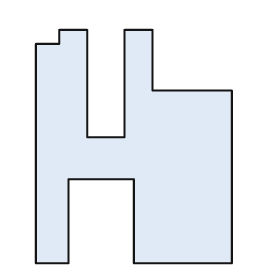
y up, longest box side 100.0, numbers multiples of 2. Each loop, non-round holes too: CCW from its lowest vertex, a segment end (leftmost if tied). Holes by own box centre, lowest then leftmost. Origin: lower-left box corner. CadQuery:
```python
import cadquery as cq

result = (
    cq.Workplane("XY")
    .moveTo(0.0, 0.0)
    .lineTo(14.0, 0.0)
    .lineTo(14.0, 36.0)
    .lineTo(42.0, 36.0)
    .lineTo(42.0, 0.0)
    .lineTo(84.0, 0.0)
    .lineTo(84.0, 74.0)
    .lineTo(50.0, 74.0)
    .lineTo(50.0, 100.0)
    .lineTo(38.0, 100.0)
    .lineTo(38.0, 54.0)
    .lineTo(22.0, 54.0)
    .lineTo(22.0, 100.0)
    .lineTo(10.0, 100.0)
    .lineTo(10.0, 94.0)
    .lineTo(0.0, 94.0)
    .close()
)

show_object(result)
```